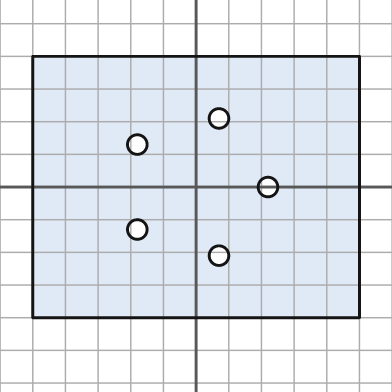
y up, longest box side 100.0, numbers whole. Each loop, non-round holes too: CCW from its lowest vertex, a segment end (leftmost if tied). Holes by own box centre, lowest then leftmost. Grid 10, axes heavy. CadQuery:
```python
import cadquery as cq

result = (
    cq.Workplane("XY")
    .moveTo(-50.0, -40.0)
    .lineTo(50.0, -40.0)
    .lineTo(50.0, 40.0)
    .lineTo(-50.0, 40.0)
    .close()
    .moveTo(7.0, -21.0)
    .circle(3.0)
    .moveTo(-18.0, -13.0)
    .circle(3.0)
    .moveTo(22.0, 0.0)
    .circle(3.0)
    .moveTo(-18.0, 13.0)
    .circle(3.0)
    .moveTo(7.0, 21.0)
    .circle(3.0)
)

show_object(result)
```